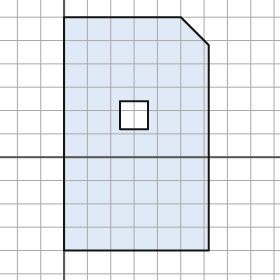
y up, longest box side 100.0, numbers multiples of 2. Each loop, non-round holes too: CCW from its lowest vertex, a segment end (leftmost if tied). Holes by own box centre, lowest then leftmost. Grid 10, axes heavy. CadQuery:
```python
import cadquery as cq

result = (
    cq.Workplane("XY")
    .moveTo(0.0, -40.0)
    .lineTo(62.0, -40.0)
    .lineTo(62.0, 48.0)
    .lineTo(50.0, 60.0)
    .lineTo(0.0, 60.0)
    .close()
    .moveTo(24.0, 12.0)
    .lineTo(36.0, 12.0)
    .lineTo(36.0, 24.0)
    .lineTo(24.0, 24.0)
    .close()
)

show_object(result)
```